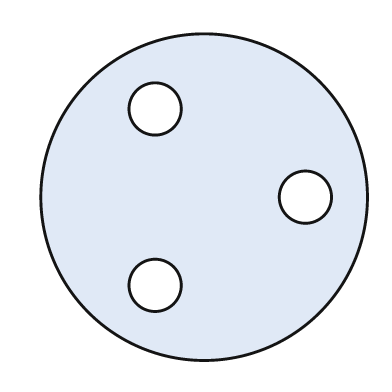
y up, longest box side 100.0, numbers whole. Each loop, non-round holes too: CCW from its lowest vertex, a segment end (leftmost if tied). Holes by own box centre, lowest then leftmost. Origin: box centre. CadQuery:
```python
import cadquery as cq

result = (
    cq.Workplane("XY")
    .moveTo(0.0, 0.0)
    .circle(50.0)
    .moveTo(-15.0, -27.0)
    .circle(8.0)
    .moveTo(31.0, 0.0)
    .circle(8.0)
    .moveTo(-15.0, 27.0)
    .circle(8.0)
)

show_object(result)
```